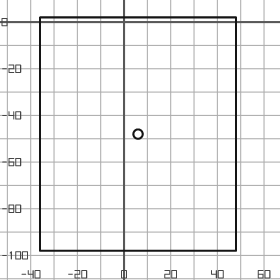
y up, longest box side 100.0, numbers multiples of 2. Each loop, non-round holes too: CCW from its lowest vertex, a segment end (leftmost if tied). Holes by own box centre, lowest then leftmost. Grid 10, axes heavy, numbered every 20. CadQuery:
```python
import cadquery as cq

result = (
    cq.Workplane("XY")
    .moveTo(-36.0, -98.0)
    .lineTo(48.0, -98.0)
    .lineTo(48.0, 2.0)
    .lineTo(-36.0, 2.0)
    .close()
    .moveTo(6.0, -48.0)
    .circle(2.0)
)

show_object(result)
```